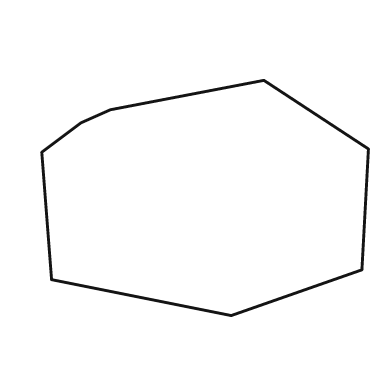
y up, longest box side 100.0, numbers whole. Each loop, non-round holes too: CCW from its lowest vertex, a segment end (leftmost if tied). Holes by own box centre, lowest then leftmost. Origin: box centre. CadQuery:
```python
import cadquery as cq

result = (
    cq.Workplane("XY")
    .moveTo(8.0, -36.0)
    .lineTo(48.0, -22.0)
    .lineTo(50.0, 15.0)
    .lineTo(18.0, 36.0)
    .lineTo(-29.0, 27.0)
    .lineTo(-38.0, 23.0)
    .lineTo(-50.0, 14.0)
    .lineTo(-47.0, -25.0)
    .close()
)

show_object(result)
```